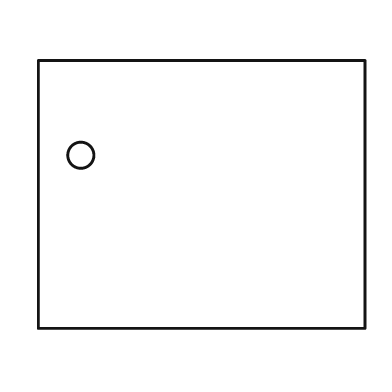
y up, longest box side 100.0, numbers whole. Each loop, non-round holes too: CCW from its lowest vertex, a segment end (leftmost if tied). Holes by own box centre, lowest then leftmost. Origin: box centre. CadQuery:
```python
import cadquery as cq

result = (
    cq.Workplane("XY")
    .moveTo(-50.0, -41.0)
    .lineTo(50.0, -41.0)
    .lineTo(50.0, 41.0)
    .lineTo(-50.0, 41.0)
    .close()
    .moveTo(-37.0, 12.0)
    .circle(4.0)
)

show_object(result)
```